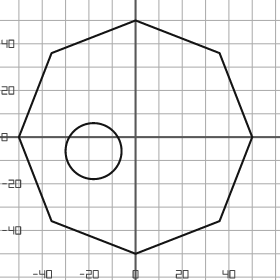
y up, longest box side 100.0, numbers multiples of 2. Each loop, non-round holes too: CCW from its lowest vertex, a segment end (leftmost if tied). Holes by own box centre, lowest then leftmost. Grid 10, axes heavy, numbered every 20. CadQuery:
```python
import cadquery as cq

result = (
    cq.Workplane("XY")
    .moveTo(0.0, -50.0)
    .lineTo(36.0, -36.0)
    .lineTo(50.0, 0.0)
    .lineTo(36.0, 36.0)
    .lineTo(0.0, 50.0)
    .lineTo(-36.0, 36.0)
    .lineTo(-50.0, 0.0)
    .lineTo(-36.0, -36.0)
    .close()
    .moveTo(-18.0, -6.0)
    .circle(12.0)
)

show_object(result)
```